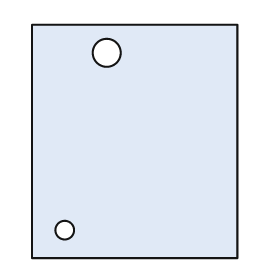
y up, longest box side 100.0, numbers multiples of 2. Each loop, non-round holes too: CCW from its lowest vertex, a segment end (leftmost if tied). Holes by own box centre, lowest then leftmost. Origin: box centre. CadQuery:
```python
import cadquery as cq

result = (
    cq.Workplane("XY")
    .moveTo(-44.0, -50.0)
    .lineTo(44.0, -50.0)
    .lineTo(44.0, 50.0)
    .lineTo(-44.0, 50.0)
    .close()
    .moveTo(-30.0, -38.0)
    .circle(4.0)
    .moveTo(-12.0, 38.0)
    .circle(6.0)
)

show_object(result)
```